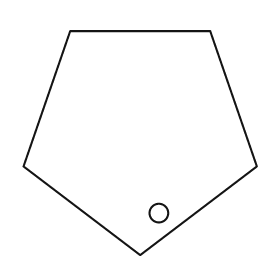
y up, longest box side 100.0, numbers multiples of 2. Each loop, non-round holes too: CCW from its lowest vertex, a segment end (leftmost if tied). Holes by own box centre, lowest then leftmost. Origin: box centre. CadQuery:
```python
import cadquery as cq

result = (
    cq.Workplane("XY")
    .moveTo(0.0, -48.0)
    .lineTo(50.0, -10.0)
    .lineTo(30.0, 48.0)
    .lineTo(-30.0, 48.0)
    .lineTo(-50.0, -10.0)
    .close()
    .moveTo(8.0, -30.0)
    .circle(4.0)
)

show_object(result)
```